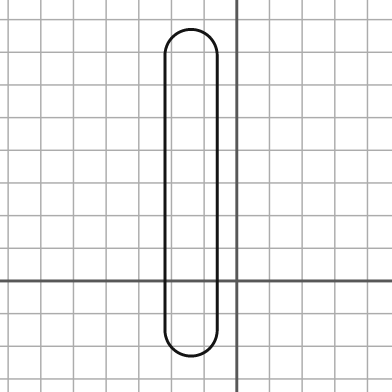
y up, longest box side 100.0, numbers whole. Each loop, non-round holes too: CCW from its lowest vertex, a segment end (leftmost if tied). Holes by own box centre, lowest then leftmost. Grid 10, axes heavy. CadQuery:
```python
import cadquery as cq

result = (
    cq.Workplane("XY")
    .moveTo(-22.0, -15.0)
    .threePointArc((-14.0, -23.0), (-6.0, -15.0))
    .lineTo(-6.0, 69.0)
    .threePointArc((-14.0, 77.0), (-22.0, 69.0))
    .close()
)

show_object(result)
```